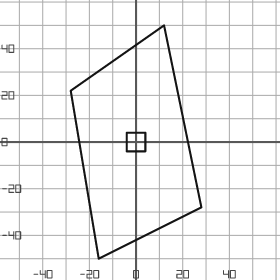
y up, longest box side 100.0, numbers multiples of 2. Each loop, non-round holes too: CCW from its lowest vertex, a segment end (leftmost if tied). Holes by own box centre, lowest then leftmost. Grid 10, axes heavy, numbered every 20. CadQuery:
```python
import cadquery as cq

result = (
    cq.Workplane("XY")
    .moveTo(-16.0, -50.0)
    .lineTo(28.0, -28.0)
    .lineTo(12.0, 50.0)
    .lineTo(-28.0, 22.0)
    .close()
    .moveTo(-4.0, -4.0)
    .lineTo(4.0, -4.0)
    .lineTo(4.0, 4.0)
    .lineTo(-4.0, 4.0)
    .close()
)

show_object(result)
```